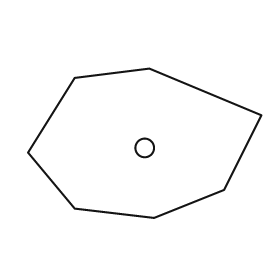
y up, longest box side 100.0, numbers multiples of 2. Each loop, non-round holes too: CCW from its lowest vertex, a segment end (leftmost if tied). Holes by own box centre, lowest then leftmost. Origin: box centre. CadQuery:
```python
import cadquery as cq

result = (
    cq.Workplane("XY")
    .moveTo(4.0, -32.0)
    .lineTo(34.0, -20.0)
    .lineTo(50.0, 12.0)
    .lineTo(2.0, 32.0)
    .lineTo(-30.0, 28.0)
    .lineTo(-50.0, -4.0)
    .lineTo(-30.0, -28.0)
    .close()
    .moveTo(0.0, -2.0)
    .circle(4.0)
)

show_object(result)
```